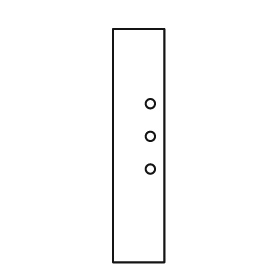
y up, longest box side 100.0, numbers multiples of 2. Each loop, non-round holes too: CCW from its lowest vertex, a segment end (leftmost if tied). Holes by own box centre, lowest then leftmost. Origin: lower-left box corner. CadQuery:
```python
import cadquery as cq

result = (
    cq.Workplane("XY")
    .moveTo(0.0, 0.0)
    .lineTo(22.0, 0.0)
    .lineTo(22.0, 100.0)
    .lineTo(0.0, 100.0)
    .close()
    .moveTo(16.0, 40.0)
    .circle(2.0)
    .moveTo(16.0, 54.0)
    .circle(2.0)
    .moveTo(16.0, 68.0)
    .circle(2.0)
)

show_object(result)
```